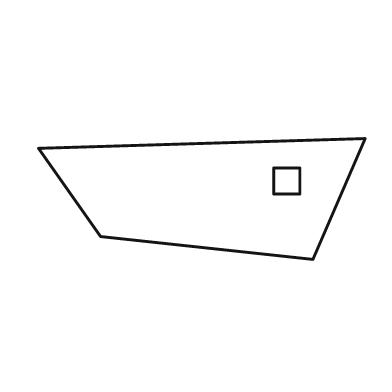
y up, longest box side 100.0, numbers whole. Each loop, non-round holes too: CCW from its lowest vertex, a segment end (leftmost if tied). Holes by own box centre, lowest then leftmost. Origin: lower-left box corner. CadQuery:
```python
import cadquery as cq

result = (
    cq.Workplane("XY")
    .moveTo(84.0, 0.0)
    .lineTo(100.0, 37.0)
    .lineTo(0.0, 34.0)
    .lineTo(19.0, 7.0)
    .close()
    .moveTo(72.0, 20.0)
    .lineTo(80.0, 20.0)
    .lineTo(80.0, 28.0)
    .lineTo(72.0, 28.0)
    .close()
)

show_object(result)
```